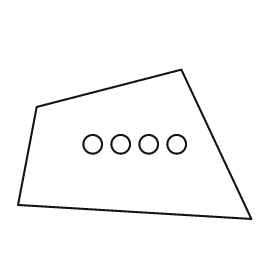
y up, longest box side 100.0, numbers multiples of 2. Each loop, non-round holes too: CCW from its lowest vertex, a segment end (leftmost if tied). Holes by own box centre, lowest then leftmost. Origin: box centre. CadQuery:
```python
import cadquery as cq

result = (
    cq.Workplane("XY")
    .moveTo(50.0, -32.0)
    .lineTo(20.0, 32.0)
    .lineTo(-42.0, 16.0)
    .lineTo(-50.0, -26.0)
    .close()
    .moveTo(-18.0, 0.0)
    .circle(4.0)
    .moveTo(-6.0, 0.0)
    .circle(4.0)
    .moveTo(6.0, 0.0)
    .circle(4.0)
    .moveTo(18.0, 0.0)
    .circle(4.0)
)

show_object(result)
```